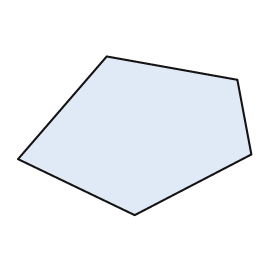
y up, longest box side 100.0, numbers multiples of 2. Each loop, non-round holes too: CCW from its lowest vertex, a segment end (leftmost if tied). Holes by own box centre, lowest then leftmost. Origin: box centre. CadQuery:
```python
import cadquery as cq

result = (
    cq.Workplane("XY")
    .moveTo(0.0, -34.0)
    .lineTo(50.0, -8.0)
    .lineTo(44.0, 24.0)
    .lineTo(-12.0, 34.0)
    .lineTo(-50.0, -10.0)
    .close()
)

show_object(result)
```